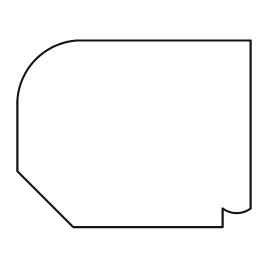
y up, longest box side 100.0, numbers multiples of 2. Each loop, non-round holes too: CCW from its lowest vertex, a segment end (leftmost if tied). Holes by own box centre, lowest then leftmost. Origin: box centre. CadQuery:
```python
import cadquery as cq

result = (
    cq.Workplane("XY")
    .moveTo(-26.0, -40.0)
    .lineTo(38.0, -40.0)
    .lineTo(38.0, -32.0)
    .threePointArc((44.0, -34.0), (50.0, -32.0))
    .lineTo(50.0, 40.0)
    .lineTo(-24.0, 40.0)
    .threePointArc((-42.0, 32.0), (-50.0, 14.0))
    .lineTo(-50.0, -16.0)
    .close()
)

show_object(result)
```